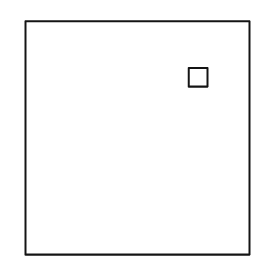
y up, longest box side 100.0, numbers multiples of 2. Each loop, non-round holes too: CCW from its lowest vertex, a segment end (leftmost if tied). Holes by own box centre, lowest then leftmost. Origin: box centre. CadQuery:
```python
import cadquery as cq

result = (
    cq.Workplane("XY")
    .moveTo(-48.0, -50.0)
    .lineTo(48.0, -50.0)
    .lineTo(48.0, 50.0)
    .lineTo(-48.0, 50.0)
    .close()
    .moveTo(22.0, 22.0)
    .lineTo(30.0, 22.0)
    .lineTo(30.0, 30.0)
    .lineTo(22.0, 30.0)
    .close()
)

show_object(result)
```